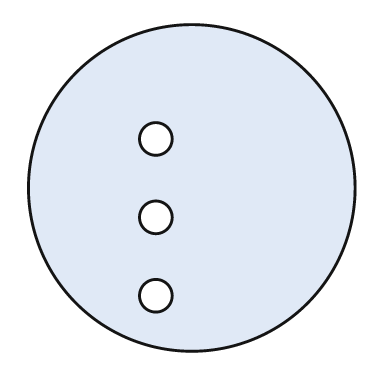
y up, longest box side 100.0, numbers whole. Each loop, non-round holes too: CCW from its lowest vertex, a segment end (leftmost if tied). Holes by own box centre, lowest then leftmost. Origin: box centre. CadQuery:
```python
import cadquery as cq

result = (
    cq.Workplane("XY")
    .moveTo(0.0, 0.0)
    .circle(50.0)
    .moveTo(-11.0, -33.0)
    .circle(5.0)
    .moveTo(-11.0, -9.0)
    .circle(5.0)
    .moveTo(-11.0, 15.0)
    .circle(5.0)
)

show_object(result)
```